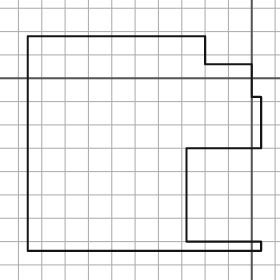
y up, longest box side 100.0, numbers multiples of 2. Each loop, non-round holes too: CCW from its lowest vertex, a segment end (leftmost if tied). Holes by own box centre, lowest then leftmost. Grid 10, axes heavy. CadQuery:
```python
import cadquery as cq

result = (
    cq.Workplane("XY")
    .moveTo(-96.0, -74.0)
    .lineTo(4.0, -74.0)
    .lineTo(4.0, -70.0)
    .lineTo(-28.0, -70.0)
    .lineTo(-28.0, -30.0)
    .lineTo(4.0, -30.0)
    .lineTo(4.0, -8.0)
    .lineTo(0.0, -8.0)
    .lineTo(0.0, 6.0)
    .lineTo(-20.0, 6.0)
    .lineTo(-20.0, 18.0)
    .lineTo(-96.0, 18.0)
    .close()
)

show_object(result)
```